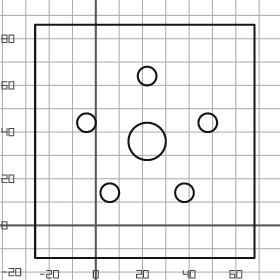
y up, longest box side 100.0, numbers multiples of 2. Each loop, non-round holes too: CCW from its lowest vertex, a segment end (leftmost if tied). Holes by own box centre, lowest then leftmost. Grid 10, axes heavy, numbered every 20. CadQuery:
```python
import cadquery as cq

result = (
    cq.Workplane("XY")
    .moveTo(-26.0, -14.0)
    .lineTo(68.0, -14.0)
    .lineTo(68.0, 86.0)
    .lineTo(-26.0, 86.0)
    .close()
    .moveTo(6.0, 14.0)
    .circle(4.0)
    .moveTo(38.0, 14.0)
    .circle(4.0)
    .moveTo(22.0, 36.0)
    .circle(8.0)
    .moveTo(-4.0, 44.0)
    .circle(4.0)
    .moveTo(48.0, 44.0)
    .circle(4.0)
    .moveTo(22.0, 64.0)
    .circle(4.0)
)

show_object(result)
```